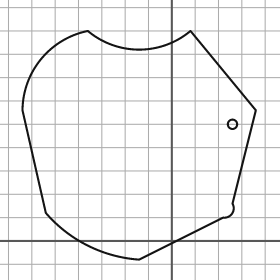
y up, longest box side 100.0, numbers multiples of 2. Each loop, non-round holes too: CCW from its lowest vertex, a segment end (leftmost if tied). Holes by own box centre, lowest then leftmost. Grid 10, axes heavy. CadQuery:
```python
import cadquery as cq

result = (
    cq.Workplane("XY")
    .moveTo(-14.0, -8.0)
    .lineTo(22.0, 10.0)
    .threePointArc((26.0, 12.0), (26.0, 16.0))
    .lineTo(36.0, 56.0)
    .lineTo(8.0, 90.0)
    .threePointArc((-14.0, 82.0), (-36.0, 90.0))
    .threePointArc((-56.0, 78.0), (-64.0, 56.0))
    .lineTo(-54.0, 12.0)
    .threePointArc((-36.0, -2.0), (-14.0, -8.0))
    .close()
    .moveTo(26.0, 50.0)
    .circle(2.0)
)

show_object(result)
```